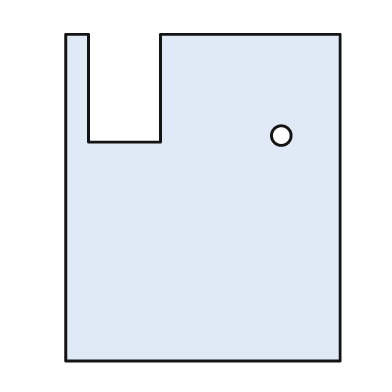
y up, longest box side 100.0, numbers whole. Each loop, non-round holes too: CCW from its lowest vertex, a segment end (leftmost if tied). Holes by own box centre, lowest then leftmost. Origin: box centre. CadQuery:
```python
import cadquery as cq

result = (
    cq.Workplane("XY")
    .moveTo(-42.0, -50.0)
    .lineTo(42.0, -50.0)
    .lineTo(42.0, 50.0)
    .lineTo(-13.0, 50.0)
    .lineTo(-13.0, 17.0)
    .lineTo(-35.0, 17.0)
    .lineTo(-35.0, 50.0)
    .lineTo(-42.0, 50.0)
    .close()
    .moveTo(24.0, 19.0)
    .circle(3.0)
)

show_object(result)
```